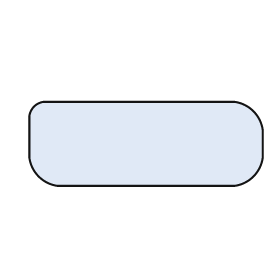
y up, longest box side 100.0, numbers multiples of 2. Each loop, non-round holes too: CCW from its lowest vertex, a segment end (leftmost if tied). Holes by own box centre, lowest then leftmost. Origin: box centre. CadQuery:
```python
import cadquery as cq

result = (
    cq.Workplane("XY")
    .moveTo(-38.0, -18.0)
    .lineTo(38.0, -18.0)
    .threePointArc((46.0, -14.0), (50.0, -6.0))
    .lineTo(50.0, 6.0)
    .threePointArc((46.0, 14.0), (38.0, 18.0))
    .lineTo(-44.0, 18.0)
    .threePointArc((-48.0, 16.0), (-50.0, 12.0))
    .lineTo(-50.0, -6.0)
    .threePointArc((-46.0, -14.0), (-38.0, -18.0))
    .close()
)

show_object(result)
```